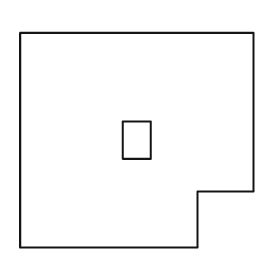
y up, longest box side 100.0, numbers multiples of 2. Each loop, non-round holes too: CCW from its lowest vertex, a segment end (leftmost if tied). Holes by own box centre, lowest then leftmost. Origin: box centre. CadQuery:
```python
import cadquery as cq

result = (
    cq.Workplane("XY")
    .moveTo(-50.0, -46.0)
    .lineTo(26.0, -46.0)
    .lineTo(26.0, -22.0)
    .lineTo(50.0, -22.0)
    .lineTo(50.0, 46.0)
    .lineTo(-50.0, 46.0)
    .close()
    .moveTo(-6.0, -8.0)
    .lineTo(6.0, -8.0)
    .lineTo(6.0, 8.0)
    .lineTo(-6.0, 8.0)
    .close()
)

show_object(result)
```